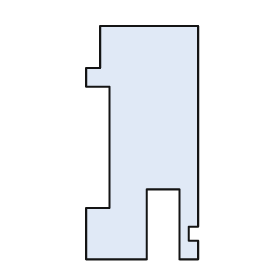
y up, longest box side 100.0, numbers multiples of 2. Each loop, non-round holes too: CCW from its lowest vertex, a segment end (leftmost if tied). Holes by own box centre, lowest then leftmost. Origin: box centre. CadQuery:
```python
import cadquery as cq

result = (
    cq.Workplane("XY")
    .moveTo(-24.0, -50.0)
    .lineTo(2.0, -50.0)
    .lineTo(2.0, -20.0)
    .lineTo(16.0, -20.0)
    .lineTo(16.0, -50.0)
    .lineTo(24.0, -50.0)
    .lineTo(24.0, -42.0)
    .lineTo(20.0, -42.0)
    .lineTo(20.0, -36.0)
    .lineTo(24.0, -36.0)
    .lineTo(24.0, 50.0)
    .lineTo(-18.0, 50.0)
    .lineTo(-18.0, 32.0)
    .lineTo(-24.0, 32.0)
    .lineTo(-24.0, 24.0)
    .lineTo(-14.0, 24.0)
    .lineTo(-14.0, -28.0)
    .lineTo(-24.0, -28.0)
    .close()
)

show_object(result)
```